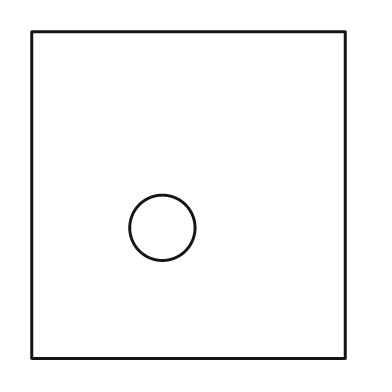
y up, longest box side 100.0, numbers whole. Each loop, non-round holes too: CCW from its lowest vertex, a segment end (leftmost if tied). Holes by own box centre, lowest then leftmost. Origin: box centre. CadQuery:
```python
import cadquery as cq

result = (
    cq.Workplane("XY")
    .moveTo(-48.0, -50.0)
    .lineTo(48.0, -50.0)
    .lineTo(48.0, 50.0)
    .lineTo(-48.0, 50.0)
    .close()
    .moveTo(-8.0, -10.0)
    .circle(10.0)
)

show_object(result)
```